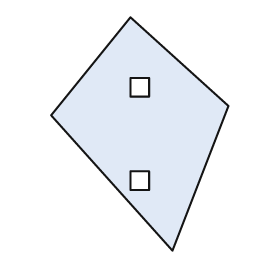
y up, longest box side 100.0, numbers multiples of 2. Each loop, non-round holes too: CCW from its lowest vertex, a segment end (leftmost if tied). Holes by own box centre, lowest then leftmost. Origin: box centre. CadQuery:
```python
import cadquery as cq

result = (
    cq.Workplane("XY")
    .moveTo(14.0, -50.0)
    .lineTo(38.0, 12.0)
    .lineTo(-4.0, 50.0)
    .lineTo(-38.0, 8.0)
    .close()
    .moveTo(-4.0, -24.0)
    .lineTo(4.0, -24.0)
    .lineTo(4.0, -16.0)
    .lineTo(-4.0, -16.0)
    .close()
    .moveTo(-4.0, 16.0)
    .lineTo(4.0, 16.0)
    .lineTo(4.0, 24.0)
    .lineTo(-4.0, 24.0)
    .close()
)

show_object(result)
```